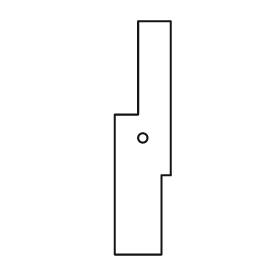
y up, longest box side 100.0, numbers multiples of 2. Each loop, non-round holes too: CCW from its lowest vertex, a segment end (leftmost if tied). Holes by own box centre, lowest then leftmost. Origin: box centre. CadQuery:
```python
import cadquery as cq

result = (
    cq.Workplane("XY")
    .moveTo(-12.0, -50.0)
    .lineTo(8.0, -50.0)
    .lineTo(8.0, -16.0)
    .lineTo(12.0, -16.0)
    .lineTo(12.0, 50.0)
    .lineTo(-2.0, 50.0)
    .lineTo(-2.0, 10.0)
    .lineTo(-12.0, 10.0)
    .close()
    .moveTo(0.0, 0.0)
    .circle(2.0)
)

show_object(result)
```